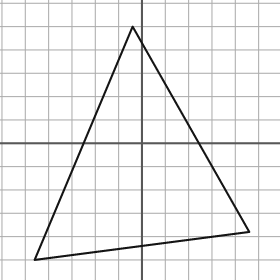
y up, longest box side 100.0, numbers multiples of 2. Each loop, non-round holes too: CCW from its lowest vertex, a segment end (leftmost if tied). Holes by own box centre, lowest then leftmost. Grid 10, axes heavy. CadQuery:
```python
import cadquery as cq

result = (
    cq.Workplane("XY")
    .moveTo(-46.0, -50.0)
    .lineTo(46.0, -38.0)
    .lineTo(-4.0, 50.0)
    .close()
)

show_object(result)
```